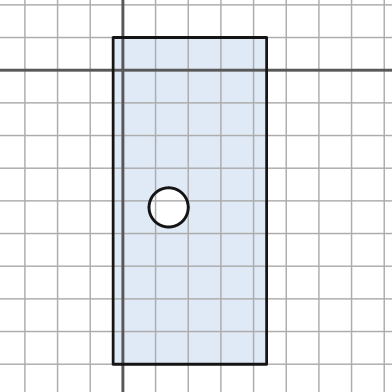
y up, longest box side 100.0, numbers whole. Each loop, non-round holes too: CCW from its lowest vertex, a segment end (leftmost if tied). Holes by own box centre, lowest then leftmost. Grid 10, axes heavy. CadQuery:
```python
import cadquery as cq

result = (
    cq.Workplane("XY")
    .moveTo(-3.0, -90.0)
    .lineTo(44.0, -90.0)
    .lineTo(44.0, 10.0)
    .lineTo(-3.0, 10.0)
    .close()
    .moveTo(14.0, -42.0)
    .circle(6.0)
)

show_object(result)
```